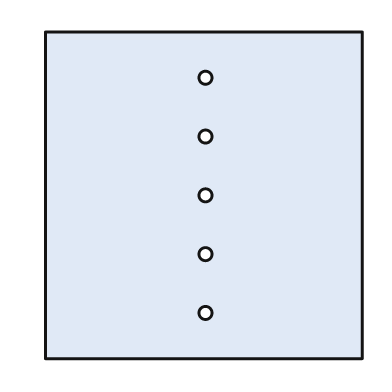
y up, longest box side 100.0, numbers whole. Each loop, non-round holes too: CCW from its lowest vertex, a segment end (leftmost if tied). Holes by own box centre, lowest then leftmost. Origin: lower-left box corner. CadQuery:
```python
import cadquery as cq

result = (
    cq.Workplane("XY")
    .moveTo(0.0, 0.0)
    .lineTo(97.0, 0.0)
    .lineTo(97.0, 100.0)
    .lineTo(0.0, 100.0)
    .close()
    .moveTo(49.0, 14.0)
    .circle(2.0)
    .moveTo(49.0, 32.0)
    .circle(2.0)
    .moveTo(49.0, 50.0)
    .circle(2.0)
    .moveTo(49.0, 68.0)
    .circle(2.0)
    .moveTo(49.0, 86.0)
    .circle(2.0)
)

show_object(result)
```